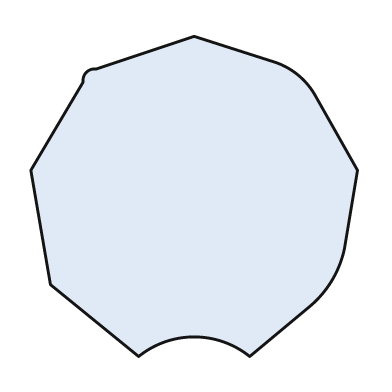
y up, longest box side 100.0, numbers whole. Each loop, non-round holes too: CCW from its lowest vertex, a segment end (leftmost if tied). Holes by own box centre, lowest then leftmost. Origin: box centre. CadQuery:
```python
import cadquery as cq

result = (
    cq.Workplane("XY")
    .moveTo(-17.0, -49.0)
    .threePointArc((0.0, -43.0), (17.0, -49.0))
    .lineTo(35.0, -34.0)
    .threePointArc((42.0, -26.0), (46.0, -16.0))
    .lineTo(50.0, 8.0)
    .lineTo(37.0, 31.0)
    .threePointArc((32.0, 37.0), (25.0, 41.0))
    .lineTo(0.0, 49.0)
    .lineTo(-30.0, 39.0)
    .threePointArc((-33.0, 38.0), (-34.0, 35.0))
    .lineTo(-50.0, 8.0)
    .lineTo(-44.0, -27.0)
    .close()
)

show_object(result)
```